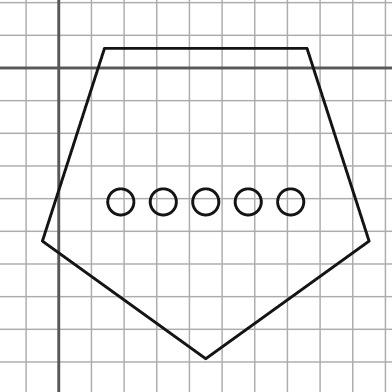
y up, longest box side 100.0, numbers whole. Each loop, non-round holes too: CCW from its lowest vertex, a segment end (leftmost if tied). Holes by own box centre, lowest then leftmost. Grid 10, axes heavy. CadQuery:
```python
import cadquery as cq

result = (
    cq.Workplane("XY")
    .moveTo(45.0, -89.0)
    .lineTo(95.0, -53.0)
    .lineTo(76.0, 6.0)
    .lineTo(14.0, 6.0)
    .lineTo(-5.0, -53.0)
    .close()
    .moveTo(19.0, -41.0)
    .circle(4.0)
    .moveTo(32.0, -41.0)
    .circle(4.0)
    .moveTo(45.0, -41.0)
    .circle(4.0)
    .moveTo(58.0, -41.0)
    .circle(4.0)
    .moveTo(71.0, -41.0)
    .circle(4.0)
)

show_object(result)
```